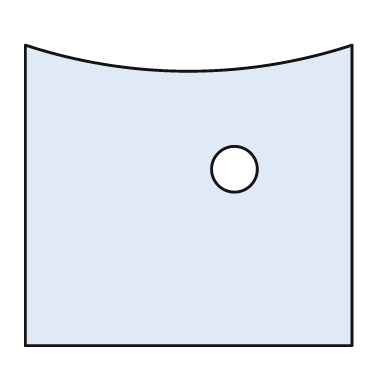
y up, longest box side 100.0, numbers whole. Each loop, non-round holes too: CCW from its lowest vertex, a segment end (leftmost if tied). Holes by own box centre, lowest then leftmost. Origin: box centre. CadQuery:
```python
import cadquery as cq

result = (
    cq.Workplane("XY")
    .moveTo(-50.0, -46.0)
    .lineTo(50.0, -46.0)
    .lineTo(50.0, 46.0)
    .threePointArc((0.0, 38.0), (-50.0, 46.0))
    .close()
    .moveTo(14.0, 8.0)
    .circle(7.0)
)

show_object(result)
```